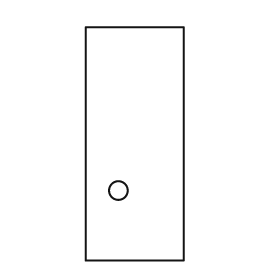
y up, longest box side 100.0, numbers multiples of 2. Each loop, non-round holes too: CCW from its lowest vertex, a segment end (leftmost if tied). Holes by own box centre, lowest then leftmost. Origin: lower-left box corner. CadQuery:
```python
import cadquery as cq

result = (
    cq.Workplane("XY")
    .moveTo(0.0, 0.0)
    .lineTo(42.0, 0.0)
    .lineTo(42.0, 100.0)
    .lineTo(0.0, 100.0)
    .close()
    .moveTo(14.0, 30.0)
    .circle(4.0)
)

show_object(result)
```